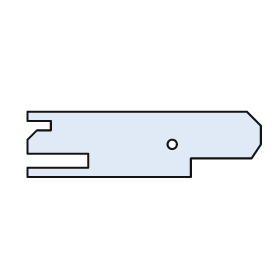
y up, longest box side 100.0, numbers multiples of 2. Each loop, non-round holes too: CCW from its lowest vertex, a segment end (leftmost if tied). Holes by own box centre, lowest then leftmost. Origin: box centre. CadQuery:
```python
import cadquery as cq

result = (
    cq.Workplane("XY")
    .moveTo(-50.0, -14.0)
    .lineTo(20.0, -14.0)
    .lineTo(20.0, -6.0)
    .lineTo(46.0, -6.0)
    .lineTo(50.0, 0.0)
    .lineTo(50.0, 8.0)
    .lineTo(44.0, 14.0)
    .lineTo(-50.0, 14.0)
    .lineTo(-50.0, 10.0)
    .lineTo(-40.0, 10.0)
    .lineTo(-40.0, 6.0)
    .lineTo(-46.0, 6.0)
    .lineTo(-50.0, 2.0)
    .lineTo(-50.0, -4.0)
    .lineTo(-24.0, -4.0)
    .lineTo(-24.0, -10.0)
    .lineTo(-50.0, -10.0)
    .close()
    .moveTo(12.0, 0.0)
    .circle(2.0)
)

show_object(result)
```